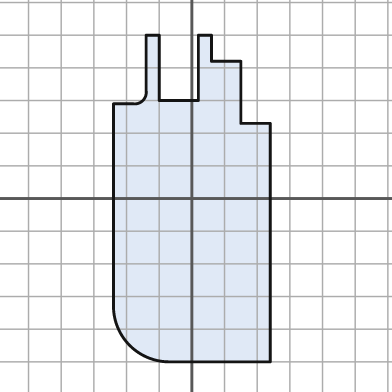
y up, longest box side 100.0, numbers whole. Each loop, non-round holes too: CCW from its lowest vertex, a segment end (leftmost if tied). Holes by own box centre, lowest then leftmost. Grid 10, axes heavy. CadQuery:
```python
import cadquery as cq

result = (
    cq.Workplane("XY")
    .moveTo(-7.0, -50.0)
    .lineTo(24.0, -50.0)
    .lineTo(24.0, 23.0)
    .lineTo(15.0, 23.0)
    .lineTo(15.0, 42.0)
    .lineTo(6.0, 42.0)
    .lineTo(6.0, 50.0)
    .lineTo(2.0, 50.0)
    .lineTo(2.0, 30.0)
    .lineTo(-10.0, 30.0)
    .lineTo(-10.0, 50.0)
    .lineTo(-14.0, 50.0)
    .lineTo(-14.0, 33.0)
    .threePointArc((-15.0, 30.0), (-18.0, 29.0))
    .lineTo(-24.0, 29.0)
    .lineTo(-24.0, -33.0)
    .threePointArc((-19.0, -45.0), (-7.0, -50.0))
    .close()
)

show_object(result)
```